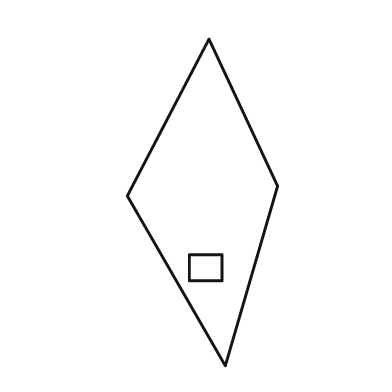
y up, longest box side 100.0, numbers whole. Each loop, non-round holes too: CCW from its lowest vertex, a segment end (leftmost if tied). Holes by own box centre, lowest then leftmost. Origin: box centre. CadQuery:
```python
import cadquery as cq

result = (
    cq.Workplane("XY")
    .moveTo(7.0, -50.0)
    .lineTo(23.0, 5.0)
    .lineTo(2.0, 50.0)
    .lineTo(-23.0, 2.0)
    .close()
    .moveTo(-4.0, -24.0)
    .lineTo(6.0, -24.0)
    .lineTo(6.0, -16.0)
    .lineTo(-4.0, -16.0)
    .close()
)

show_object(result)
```